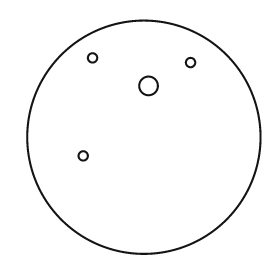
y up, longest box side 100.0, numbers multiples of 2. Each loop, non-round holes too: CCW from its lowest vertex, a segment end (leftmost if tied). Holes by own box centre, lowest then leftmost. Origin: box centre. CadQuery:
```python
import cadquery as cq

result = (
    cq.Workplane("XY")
    .moveTo(0.0, 0.0)
    .circle(50.0)
    .moveTo(-26.0, -8.0)
    .circle(2.0)
    .moveTo(2.0, 22.0)
    .circle(4.0)
    .moveTo(20.0, 32.0)
    .circle(2.0)
    .moveTo(-22.0, 34.0)
    .circle(2.0)
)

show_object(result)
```